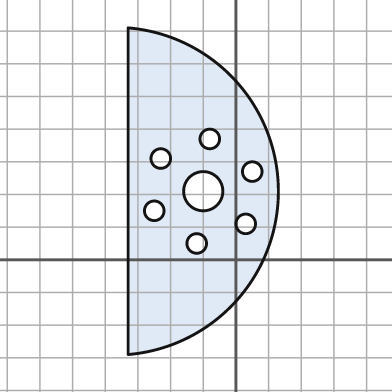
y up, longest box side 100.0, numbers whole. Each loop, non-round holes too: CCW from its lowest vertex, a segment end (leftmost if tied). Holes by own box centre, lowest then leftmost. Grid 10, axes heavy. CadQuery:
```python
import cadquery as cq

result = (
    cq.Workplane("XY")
    .moveTo(-33.0, -29.0)
    .threePointArc((13.0, 21.0), (-33.0, 71.0))
    .close()
    .moveTo(-12.0, 5.0)
    .circle(3.0)
    .moveTo(3.0, 11.0)
    .circle(3.0)
    .moveTo(-25.0, 15.0)
    .circle(3.0)
    .moveTo(-10.0, 21.0)
    .circle(6.0)
    .moveTo(5.0, 27.0)
    .circle(3.0)
    .moveTo(-23.0, 31.0)
    .circle(3.0)
    .moveTo(-8.0, 37.0)
    .circle(3.0)
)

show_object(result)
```